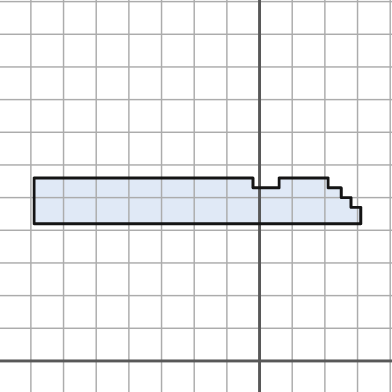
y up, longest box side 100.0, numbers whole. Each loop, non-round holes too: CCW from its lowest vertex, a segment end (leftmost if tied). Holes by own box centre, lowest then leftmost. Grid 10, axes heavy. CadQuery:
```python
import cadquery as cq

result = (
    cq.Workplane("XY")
    .moveTo(-69.0, 42.0)
    .lineTo(31.0, 42.0)
    .lineTo(31.0, 47.0)
    .lineTo(28.0, 47.0)
    .lineTo(28.0, 50.0)
    .lineTo(25.0, 50.0)
    .lineTo(25.0, 53.0)
    .lineTo(21.0, 53.0)
    .lineTo(21.0, 56.0)
    .lineTo(6.0, 56.0)
    .lineTo(6.0, 53.0)
    .lineTo(-2.0, 53.0)
    .lineTo(-2.0, 56.0)
    .lineTo(-69.0, 56.0)
    .close()
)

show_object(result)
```